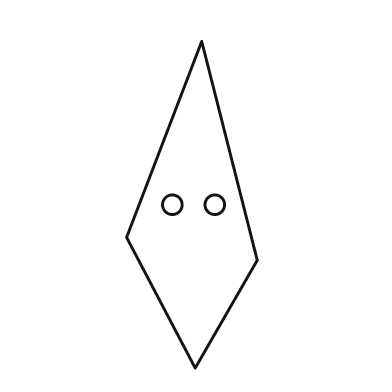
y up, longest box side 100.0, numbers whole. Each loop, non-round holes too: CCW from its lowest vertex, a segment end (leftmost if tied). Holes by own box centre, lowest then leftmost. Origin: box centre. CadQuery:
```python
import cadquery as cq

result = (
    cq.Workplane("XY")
    .moveTo(1.0, -50.0)
    .lineTo(20.0, -17.0)
    .lineTo(3.0, 50.0)
    .lineTo(-20.0, -10.0)
    .close()
    .moveTo(-6.0, 0.0)
    .circle(3.0)
    .moveTo(7.0, 0.0)
    .circle(3.0)
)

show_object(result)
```